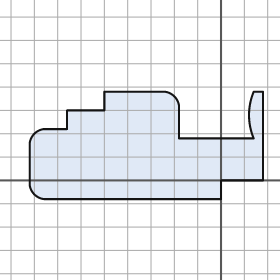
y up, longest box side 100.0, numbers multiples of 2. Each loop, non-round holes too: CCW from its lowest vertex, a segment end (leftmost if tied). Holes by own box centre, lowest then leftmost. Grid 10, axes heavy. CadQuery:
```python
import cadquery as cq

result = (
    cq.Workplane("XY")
    .moveTo(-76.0, -8.0)
    .lineTo(0.0, -8.0)
    .lineTo(0.0, 0.0)
    .lineTo(18.0, 0.0)
    .lineTo(18.0, 38.0)
    .lineTo(14.0, 38.0)
    .threePointArc((12.0, 28.0), (14.0, 18.0))
    .lineTo(-18.0, 18.0)
    .lineTo(-18.0, 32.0)
    .threePointArc((-20.0, 36.0), (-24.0, 38.0))
    .lineTo(-50.0, 38.0)
    .lineTo(-50.0, 30.0)
    .lineTo(-66.0, 30.0)
    .lineTo(-66.0, 22.0)
    .lineTo(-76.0, 22.0)
    .threePointArc((-80.0, 20.0), (-82.0, 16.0))
    .lineTo(-82.0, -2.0)
    .threePointArc((-80.0, -6.0), (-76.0, -8.0))
    .close()
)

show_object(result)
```